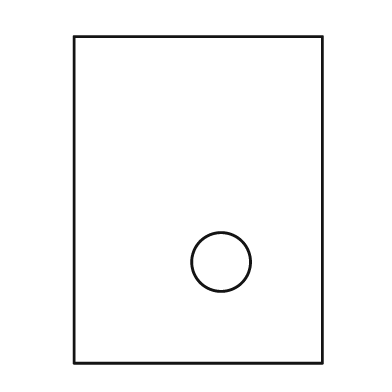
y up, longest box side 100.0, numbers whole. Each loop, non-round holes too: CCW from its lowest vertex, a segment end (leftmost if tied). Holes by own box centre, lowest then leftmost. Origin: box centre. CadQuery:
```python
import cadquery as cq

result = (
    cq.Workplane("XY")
    .moveTo(-38.0, -50.0)
    .lineTo(38.0, -50.0)
    .lineTo(38.0, 50.0)
    .lineTo(-38.0, 50.0)
    .close()
    .moveTo(7.0, -19.0)
    .circle(9.0)
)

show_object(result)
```